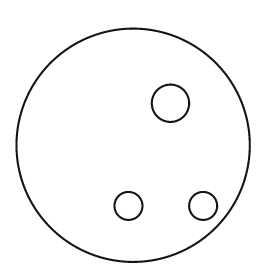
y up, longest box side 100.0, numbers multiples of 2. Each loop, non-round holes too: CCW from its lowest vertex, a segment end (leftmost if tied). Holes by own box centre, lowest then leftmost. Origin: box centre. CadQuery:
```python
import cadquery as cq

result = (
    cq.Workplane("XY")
    .moveTo(0.0, 0.0)
    .circle(50.0)
    .moveTo(-2.0, -26.0)
    .circle(6.0)
    .moveTo(30.0, -26.0)
    .circle(6.0)
    .moveTo(16.0, 18.0)
    .circle(8.0)
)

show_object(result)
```